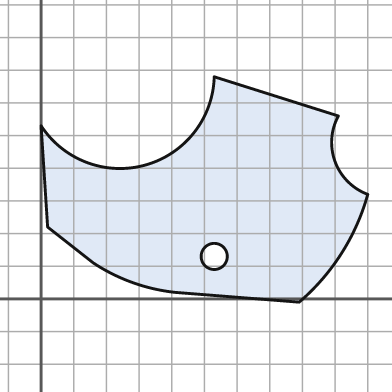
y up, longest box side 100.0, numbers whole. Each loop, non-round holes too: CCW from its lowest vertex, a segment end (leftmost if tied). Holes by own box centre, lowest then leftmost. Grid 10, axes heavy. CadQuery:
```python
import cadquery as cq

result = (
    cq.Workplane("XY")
    .moveTo(79.0, -1.0)
    .threePointArc((92.0, 14.0), (100.0, 32.0))
    .threePointArc((90.0, 42.0), (91.0, 56.0))
    .lineTo(53.0, 68.0)
    .threePointArc((32.0, 41.0), (0.0, 53.0))
    .lineTo(2.0, 22.0)
    .lineTo(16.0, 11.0)
    .threePointArc((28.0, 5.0), (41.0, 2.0))
    .close()
    .moveTo(53.0, 13.0)
    .circle(4.0)
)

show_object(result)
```